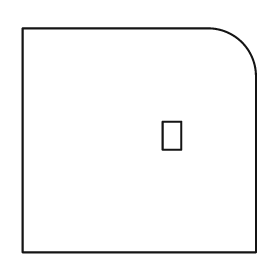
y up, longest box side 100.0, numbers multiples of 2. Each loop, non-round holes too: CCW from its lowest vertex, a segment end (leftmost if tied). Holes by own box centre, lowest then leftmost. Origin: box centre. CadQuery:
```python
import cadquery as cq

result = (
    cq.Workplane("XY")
    .moveTo(-50.0, -48.0)
    .lineTo(50.0, -48.0)
    .lineTo(50.0, 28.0)
    .threePointArc((44.0, 42.0), (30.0, 48.0))
    .lineTo(-50.0, 48.0)
    .close()
    .moveTo(10.0, -4.0)
    .lineTo(18.0, -4.0)
    .lineTo(18.0, 8.0)
    .lineTo(10.0, 8.0)
    .close()
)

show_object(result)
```